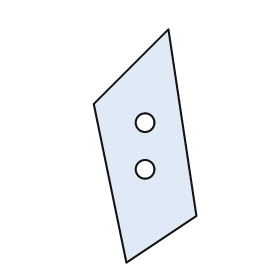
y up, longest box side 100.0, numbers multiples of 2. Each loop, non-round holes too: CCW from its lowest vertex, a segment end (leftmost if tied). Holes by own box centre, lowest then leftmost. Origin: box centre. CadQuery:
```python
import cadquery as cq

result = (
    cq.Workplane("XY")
    .moveTo(-8.0, -50.0)
    .lineTo(22.0, -30.0)
    .lineTo(10.0, 50.0)
    .lineTo(-22.0, 18.0)
    .close()
    .moveTo(0.0, -10.0)
    .circle(4.0)
    .moveTo(0.0, 10.0)
    .circle(4.0)
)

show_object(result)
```